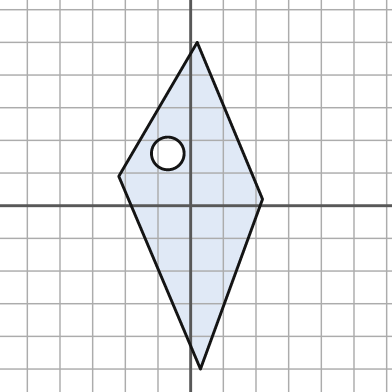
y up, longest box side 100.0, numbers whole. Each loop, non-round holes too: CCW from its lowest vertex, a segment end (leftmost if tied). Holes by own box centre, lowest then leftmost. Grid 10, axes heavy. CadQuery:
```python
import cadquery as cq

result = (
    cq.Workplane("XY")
    .moveTo(3.0, -50.0)
    .lineTo(22.0, 2.0)
    .lineTo(2.0, 50.0)
    .lineTo(-22.0, 9.0)
    .close()
    .moveTo(-7.0, 16.0)
    .circle(5.0)
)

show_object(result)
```